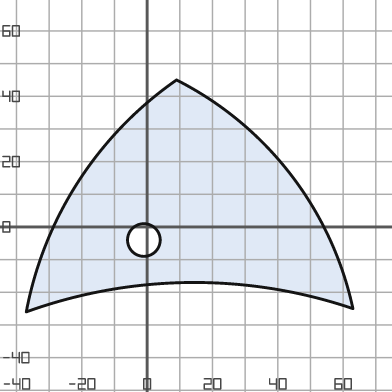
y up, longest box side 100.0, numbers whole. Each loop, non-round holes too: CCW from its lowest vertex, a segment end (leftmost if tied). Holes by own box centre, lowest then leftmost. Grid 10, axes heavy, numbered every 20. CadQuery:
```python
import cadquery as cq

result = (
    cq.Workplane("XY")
    .moveTo(-37.0, -26.0)
    .threePointArc((13.0, -17.0), (63.0, -25.0))
    .threePointArc((44.0, 16.0), (9.0, 45.0))
    .threePointArc((-21.0, 14.0), (-37.0, -26.0))
    .close()
    .moveTo(-1.0, -4.0)
    .circle(5.0)
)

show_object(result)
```